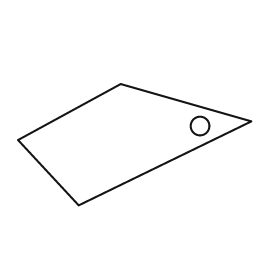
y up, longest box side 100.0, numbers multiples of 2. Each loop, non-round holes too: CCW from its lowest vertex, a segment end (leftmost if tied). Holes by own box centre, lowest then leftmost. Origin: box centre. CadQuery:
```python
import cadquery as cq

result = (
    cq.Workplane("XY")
    .moveTo(-24.0, -26.0)
    .lineTo(50.0, 10.0)
    .lineTo(-6.0, 26.0)
    .lineTo(-50.0, 2.0)
    .close()
    .moveTo(28.0, 8.0)
    .circle(4.0)
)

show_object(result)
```